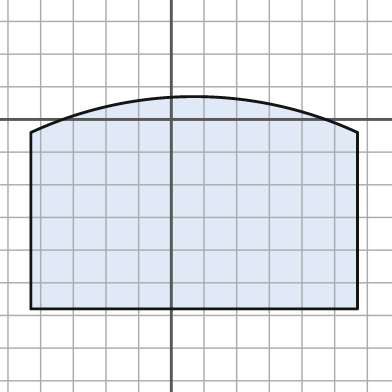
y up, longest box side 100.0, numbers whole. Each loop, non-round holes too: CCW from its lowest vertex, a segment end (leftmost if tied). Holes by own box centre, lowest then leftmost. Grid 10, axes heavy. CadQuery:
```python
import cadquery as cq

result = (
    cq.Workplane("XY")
    .moveTo(-43.0, -58.0)
    .lineTo(57.0, -58.0)
    .lineTo(57.0, -4.0)
    .threePointArc((7.0, 7.0), (-43.0, -4.0))
    .close()
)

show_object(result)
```